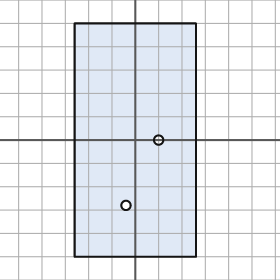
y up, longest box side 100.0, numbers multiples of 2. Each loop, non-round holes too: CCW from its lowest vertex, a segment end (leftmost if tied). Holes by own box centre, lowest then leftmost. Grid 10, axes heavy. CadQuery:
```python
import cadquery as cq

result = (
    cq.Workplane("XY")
    .moveTo(-26.0, -50.0)
    .lineTo(26.0, -50.0)
    .lineTo(26.0, 50.0)
    .lineTo(-26.0, 50.0)
    .close()
    .moveTo(-4.0, -28.0)
    .circle(2.0)
    .moveTo(10.0, 0.0)
    .circle(2.0)
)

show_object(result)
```